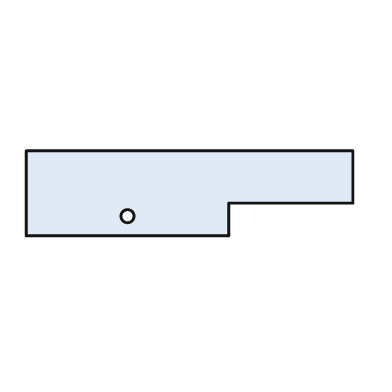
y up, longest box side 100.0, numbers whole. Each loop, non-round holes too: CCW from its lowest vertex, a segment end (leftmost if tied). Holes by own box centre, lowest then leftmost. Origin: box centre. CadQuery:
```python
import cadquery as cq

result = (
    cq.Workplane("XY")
    .moveTo(-50.0, -13.0)
    .lineTo(12.0, -13.0)
    .lineTo(12.0, -3.0)
    .lineTo(50.0, -3.0)
    .lineTo(50.0, 13.0)
    .lineTo(-50.0, 13.0)
    .close()
    .moveTo(-19.0, -7.0)
    .circle(2.0)
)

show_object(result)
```